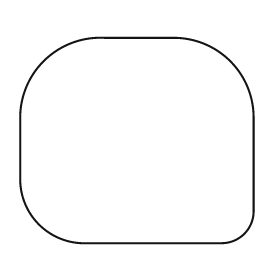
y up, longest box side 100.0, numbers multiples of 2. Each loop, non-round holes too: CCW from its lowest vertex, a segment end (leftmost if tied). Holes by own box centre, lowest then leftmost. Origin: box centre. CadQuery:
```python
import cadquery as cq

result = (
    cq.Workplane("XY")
    .moveTo(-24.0, -44.0)
    .lineTo(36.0, -44.0)
    .threePointArc((46.0, -40.0), (50.0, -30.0))
    .lineTo(50.0, 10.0)
    .threePointArc((40.0, 34.0), (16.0, 44.0))
    .lineTo(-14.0, 44.0)
    .threePointArc((-40.0, 34.0), (-50.0, 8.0))
    .lineTo(-50.0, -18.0)
    .threePointArc((-42.0, -36.0), (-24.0, -44.0))
    .close()
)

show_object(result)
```